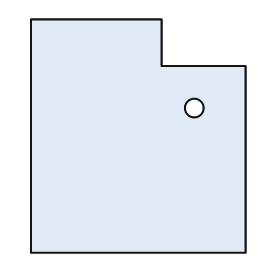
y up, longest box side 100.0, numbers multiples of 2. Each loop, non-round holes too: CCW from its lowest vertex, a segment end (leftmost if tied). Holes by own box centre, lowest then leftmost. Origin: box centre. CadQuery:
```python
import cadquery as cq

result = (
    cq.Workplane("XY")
    .moveTo(-46.0, -50.0)
    .lineTo(46.0, -50.0)
    .lineTo(46.0, 30.0)
    .lineTo(10.0, 30.0)
    .lineTo(10.0, 50.0)
    .lineTo(-46.0, 50.0)
    .close()
    .moveTo(24.0, 12.0)
    .circle(4.0)
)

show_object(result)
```